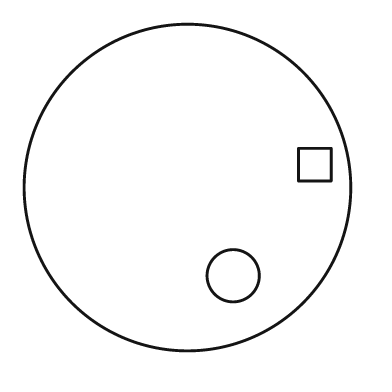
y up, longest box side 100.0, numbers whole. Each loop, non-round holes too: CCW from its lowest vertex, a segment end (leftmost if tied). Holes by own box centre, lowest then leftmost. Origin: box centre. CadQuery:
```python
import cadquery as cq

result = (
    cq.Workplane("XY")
    .moveTo(0.0, 0.0)
    .circle(50.0)
    .moveTo(14.0, -27.0)
    .circle(8.0)
    .moveTo(34.0, 2.0)
    .lineTo(44.0, 2.0)
    .lineTo(44.0, 12.0)
    .lineTo(34.0, 12.0)
    .close()
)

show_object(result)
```